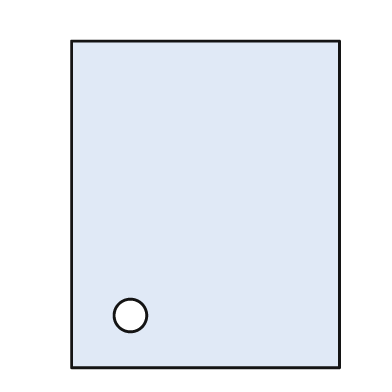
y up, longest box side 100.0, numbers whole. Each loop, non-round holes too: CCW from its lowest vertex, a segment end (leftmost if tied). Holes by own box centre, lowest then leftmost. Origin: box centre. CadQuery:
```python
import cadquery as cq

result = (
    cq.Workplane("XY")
    .moveTo(-41.0, -50.0)
    .lineTo(41.0, -50.0)
    .lineTo(41.0, 50.0)
    .lineTo(-41.0, 50.0)
    .close()
    .moveTo(-23.0, -34.0)
    .circle(5.0)
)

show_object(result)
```